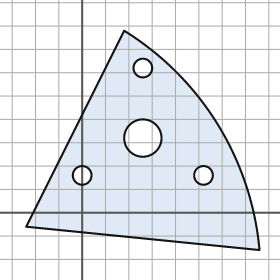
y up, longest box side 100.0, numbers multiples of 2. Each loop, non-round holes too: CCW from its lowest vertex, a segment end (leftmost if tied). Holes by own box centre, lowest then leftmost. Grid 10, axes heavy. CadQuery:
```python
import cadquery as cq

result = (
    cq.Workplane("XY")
    .moveTo(76.0, -16.0)
    .threePointArc((58.0, 38.0), (18.0, 78.0))
    .lineTo(-24.0, -6.0)
    .close()
    .moveTo(0.0, 16.0)
    .circle(4.0)
    .moveTo(52.0, 16.0)
    .circle(4.0)
    .moveTo(26.0, 32.0)
    .circle(8.0)
    .moveTo(26.0, 62.0)
    .circle(4.0)
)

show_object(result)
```